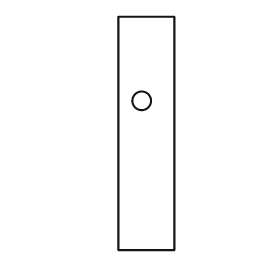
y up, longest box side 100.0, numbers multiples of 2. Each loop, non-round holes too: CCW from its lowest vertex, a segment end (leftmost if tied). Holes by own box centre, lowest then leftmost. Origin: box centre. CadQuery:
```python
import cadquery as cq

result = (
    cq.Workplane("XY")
    .moveTo(-12.0, -50.0)
    .lineTo(12.0, -50.0)
    .lineTo(12.0, 50.0)
    .lineTo(-12.0, 50.0)
    .close()
    .moveTo(-2.0, 14.0)
    .circle(4.0)
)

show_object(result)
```